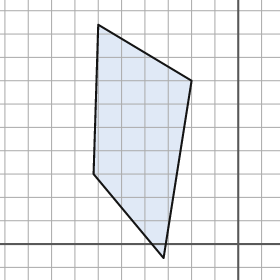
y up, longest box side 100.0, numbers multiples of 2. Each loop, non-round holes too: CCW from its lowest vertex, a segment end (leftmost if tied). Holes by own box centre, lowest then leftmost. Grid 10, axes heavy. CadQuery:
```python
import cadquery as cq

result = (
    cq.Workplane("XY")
    .moveTo(-32.0, -6.0)
    .lineTo(-20.0, 70.0)
    .lineTo(-60.0, 94.0)
    .lineTo(-62.0, 30.0)
    .close()
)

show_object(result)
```